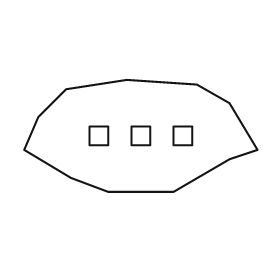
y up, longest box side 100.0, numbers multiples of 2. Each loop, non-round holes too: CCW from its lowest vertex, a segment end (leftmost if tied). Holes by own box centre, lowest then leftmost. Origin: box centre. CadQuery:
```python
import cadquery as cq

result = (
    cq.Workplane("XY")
    .moveTo(-14.0, -24.0)
    .lineTo(14.0, -24.0)
    .lineTo(38.0, -10.0)
    .lineTo(50.0, -6.0)
    .lineTo(38.0, 14.0)
    .lineTo(24.0, 22.0)
    .lineTo(-6.0, 24.0)
    .lineTo(-32.0, 20.0)
    .lineTo(-44.0, 8.0)
    .lineTo(-50.0, -6.0)
    .lineTo(-30.0, -18.0)
    .close()
    .moveTo(-22.0, -4.0)
    .lineTo(-14.0, -4.0)
    .lineTo(-14.0, 4.0)
    .lineTo(-22.0, 4.0)
    .close()
    .moveTo(-4.0, -4.0)
    .lineTo(4.0, -4.0)
    .lineTo(4.0, 4.0)
    .lineTo(-4.0, 4.0)
    .close()
    .moveTo(14.0, -4.0)
    .lineTo(22.0, -4.0)
    .lineTo(22.0, 4.0)
    .lineTo(14.0, 4.0)
    .close()
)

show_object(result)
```